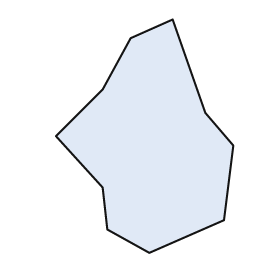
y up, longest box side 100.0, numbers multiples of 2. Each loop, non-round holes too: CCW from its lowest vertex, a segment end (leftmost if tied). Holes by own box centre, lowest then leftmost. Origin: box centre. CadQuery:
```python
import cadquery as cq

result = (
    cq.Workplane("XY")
    .moveTo(2.0, -50.0)
    .lineTo(34.0, -36.0)
    .lineTo(38.0, -4.0)
    .lineTo(26.0, 10.0)
    .lineTo(12.0, 50.0)
    .lineTo(-6.0, 42.0)
    .lineTo(-18.0, 20.0)
    .lineTo(-38.0, 0.0)
    .lineTo(-18.0, -22.0)
    .lineTo(-16.0, -40.0)
    .close()
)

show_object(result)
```